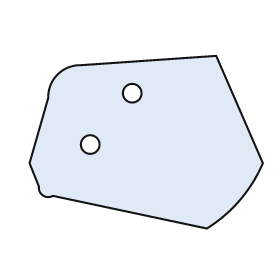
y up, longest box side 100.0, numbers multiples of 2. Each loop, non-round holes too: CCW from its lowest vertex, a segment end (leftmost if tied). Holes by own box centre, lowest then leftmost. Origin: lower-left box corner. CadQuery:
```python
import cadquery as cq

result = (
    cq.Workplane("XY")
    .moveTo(76.0, 0.0)
    .threePointArc((90.0, 12.0), (100.0, 28.0))
    .lineTo(80.0, 74.0)
    .lineTo(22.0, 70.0)
    .threePointArc((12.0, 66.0), (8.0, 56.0))
    .lineTo(0.0, 28.0)
    .lineTo(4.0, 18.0)
    .threePointArc((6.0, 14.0), (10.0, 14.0))
    .close()
    .moveTo(26.0, 36.0)
    .circle(4.0)
    .moveTo(44.0, 58.0)
    .circle(4.0)
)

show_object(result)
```